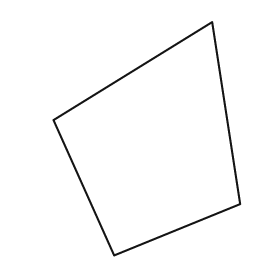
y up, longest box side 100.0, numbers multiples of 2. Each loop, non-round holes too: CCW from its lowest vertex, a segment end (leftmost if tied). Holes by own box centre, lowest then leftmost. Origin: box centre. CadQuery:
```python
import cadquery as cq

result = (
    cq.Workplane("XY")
    .moveTo(-14.0, -50.0)
    .lineTo(40.0, -28.0)
    .lineTo(28.0, 50.0)
    .lineTo(-40.0, 8.0)
    .close()
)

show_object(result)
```